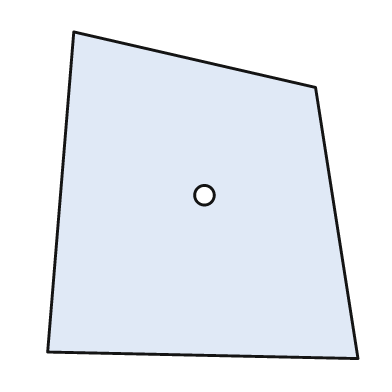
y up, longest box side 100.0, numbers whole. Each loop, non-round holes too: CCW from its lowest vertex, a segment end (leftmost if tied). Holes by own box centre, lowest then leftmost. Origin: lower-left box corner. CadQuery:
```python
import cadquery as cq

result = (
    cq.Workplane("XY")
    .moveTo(95.0, 0.0)
    .lineTo(82.0, 83.0)
    .lineTo(8.0, 100.0)
    .lineTo(0.0, 2.0)
    .close()
    .moveTo(48.0, 50.0)
    .circle(3.0)
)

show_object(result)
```